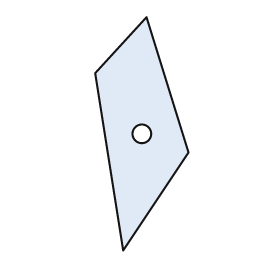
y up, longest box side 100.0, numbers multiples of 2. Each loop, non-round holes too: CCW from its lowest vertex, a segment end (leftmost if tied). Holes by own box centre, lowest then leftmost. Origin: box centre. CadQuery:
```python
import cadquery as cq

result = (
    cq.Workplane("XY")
    .moveTo(-8.0, -50.0)
    .lineTo(20.0, -8.0)
    .lineTo(2.0, 50.0)
    .lineTo(-20.0, 26.0)
    .close()
    .moveTo(0.0, 0.0)
    .circle(4.0)
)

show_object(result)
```